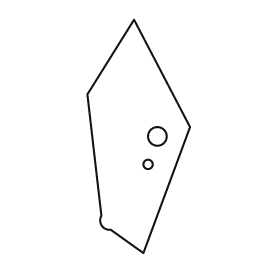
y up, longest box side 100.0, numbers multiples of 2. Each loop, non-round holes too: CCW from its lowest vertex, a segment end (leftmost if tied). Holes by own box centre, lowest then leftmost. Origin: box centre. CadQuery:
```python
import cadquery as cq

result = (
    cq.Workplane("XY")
    .moveTo(2.0, -50.0)
    .lineTo(22.0, 4.0)
    .lineTo(-2.0, 50.0)
    .lineTo(-22.0, 18.0)
    .lineTo(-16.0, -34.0)
    .threePointArc((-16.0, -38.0), (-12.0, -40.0))
    .close()
    .moveTo(4.0, -12.0)
    .circle(2.0)
    .moveTo(8.0, 0.0)
    .circle(4.0)
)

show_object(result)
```